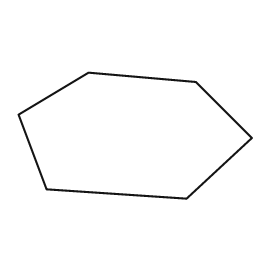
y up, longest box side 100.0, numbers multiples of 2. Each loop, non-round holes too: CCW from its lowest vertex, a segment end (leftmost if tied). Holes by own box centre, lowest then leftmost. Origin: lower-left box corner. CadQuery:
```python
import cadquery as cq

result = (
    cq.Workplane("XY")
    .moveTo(72.0, 0.0)
    .lineTo(100.0, 26.0)
    .lineTo(76.0, 50.0)
    .lineTo(30.0, 54.0)
    .lineTo(0.0, 36.0)
    .lineTo(12.0, 4.0)
    .close()
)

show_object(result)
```